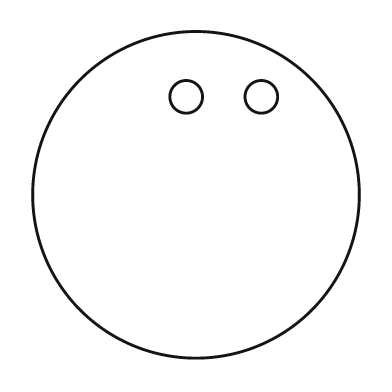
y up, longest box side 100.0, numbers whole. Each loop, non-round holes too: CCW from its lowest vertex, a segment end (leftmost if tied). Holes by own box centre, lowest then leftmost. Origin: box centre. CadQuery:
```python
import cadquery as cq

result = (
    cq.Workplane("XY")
    .moveTo(0.0, 0.0)
    .circle(50.0)
    .moveTo(-3.0, 30.0)
    .circle(5.0)
    .moveTo(20.0, 30.0)
    .circle(5.0)
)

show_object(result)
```